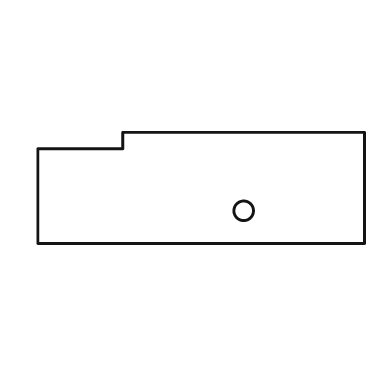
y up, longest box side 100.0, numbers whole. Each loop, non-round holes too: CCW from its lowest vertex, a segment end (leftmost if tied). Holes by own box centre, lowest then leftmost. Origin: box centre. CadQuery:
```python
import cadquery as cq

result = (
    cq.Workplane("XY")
    .moveTo(-50.0, -17.0)
    .lineTo(50.0, -17.0)
    .lineTo(50.0, 17.0)
    .lineTo(-24.0, 17.0)
    .lineTo(-24.0, 12.0)
    .lineTo(-50.0, 12.0)
    .close()
    .moveTo(13.0, -7.0)
    .circle(3.0)
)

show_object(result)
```